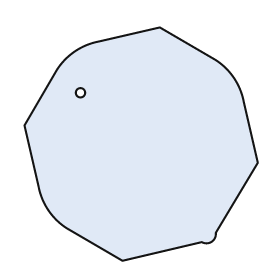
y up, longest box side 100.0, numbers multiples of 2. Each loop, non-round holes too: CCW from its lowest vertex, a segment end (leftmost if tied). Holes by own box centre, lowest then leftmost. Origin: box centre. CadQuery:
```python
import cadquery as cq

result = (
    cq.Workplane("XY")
    .moveTo(-8.0, -50.0)
    .lineTo(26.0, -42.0)
    .threePointArc((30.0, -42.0), (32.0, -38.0))
    .lineTo(50.0, -8.0)
    .lineTo(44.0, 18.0)
    .threePointArc((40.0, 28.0), (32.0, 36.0))
    .lineTo(8.0, 50.0)
    .lineTo(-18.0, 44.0)
    .threePointArc((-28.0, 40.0), (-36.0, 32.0))
    .lineTo(-50.0, 8.0)
    .lineTo(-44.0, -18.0)
    .threePointArc((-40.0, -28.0), (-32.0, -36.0))
    .close()
    .moveTo(-26.0, 22.0)
    .circle(2.0)
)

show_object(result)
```